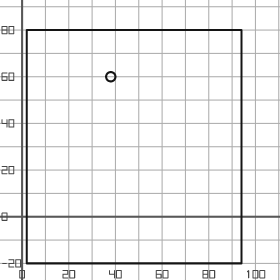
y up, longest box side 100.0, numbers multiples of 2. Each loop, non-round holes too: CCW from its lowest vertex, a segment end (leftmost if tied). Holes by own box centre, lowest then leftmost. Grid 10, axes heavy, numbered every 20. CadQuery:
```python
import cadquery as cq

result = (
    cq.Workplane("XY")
    .moveTo(2.0, -20.0)
    .lineTo(94.0, -20.0)
    .lineTo(94.0, 80.0)
    .lineTo(2.0, 80.0)
    .close()
    .moveTo(38.0, 60.0)
    .circle(2.0)
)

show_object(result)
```